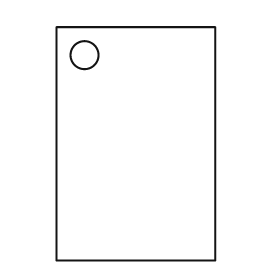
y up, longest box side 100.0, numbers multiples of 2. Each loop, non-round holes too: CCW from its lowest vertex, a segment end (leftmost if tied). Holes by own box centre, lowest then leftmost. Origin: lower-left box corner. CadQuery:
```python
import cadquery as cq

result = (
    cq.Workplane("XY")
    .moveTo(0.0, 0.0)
    .lineTo(68.0, 0.0)
    .lineTo(68.0, 100.0)
    .lineTo(0.0, 100.0)
    .close()
    .moveTo(12.0, 88.0)
    .circle(6.0)
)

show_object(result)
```